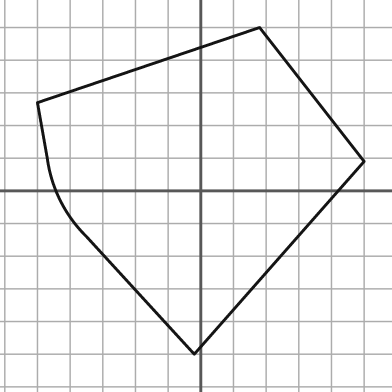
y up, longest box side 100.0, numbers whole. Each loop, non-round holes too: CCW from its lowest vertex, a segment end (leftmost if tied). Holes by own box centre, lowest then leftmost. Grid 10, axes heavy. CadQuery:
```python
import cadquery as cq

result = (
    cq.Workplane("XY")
    .moveTo(-2.0, -50.0)
    .lineTo(50.0, 9.0)
    .lineTo(18.0, 50.0)
    .lineTo(-50.0, 27.0)
    .lineTo(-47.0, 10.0)
    .threePointArc((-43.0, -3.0), (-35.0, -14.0))
    .close()
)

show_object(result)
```